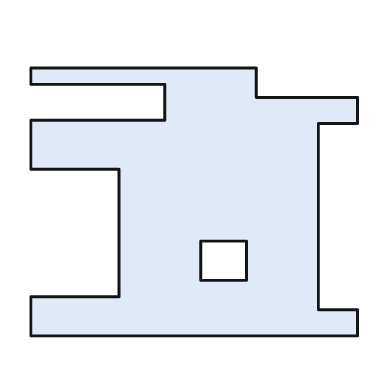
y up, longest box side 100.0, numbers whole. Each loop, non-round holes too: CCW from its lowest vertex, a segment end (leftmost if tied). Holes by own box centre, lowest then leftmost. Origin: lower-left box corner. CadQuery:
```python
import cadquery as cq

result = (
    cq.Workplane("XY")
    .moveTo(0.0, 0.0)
    .lineTo(100.0, 0.0)
    .lineTo(100.0, 8.0)
    .lineTo(88.0, 8.0)
    .lineTo(88.0, 65.0)
    .lineTo(100.0, 65.0)
    .lineTo(100.0, 73.0)
    .lineTo(69.0, 73.0)
    .lineTo(69.0, 82.0)
    .lineTo(0.0, 82.0)
    .lineTo(0.0, 77.0)
    .lineTo(41.0, 77.0)
    .lineTo(41.0, 66.0)
    .lineTo(0.0, 66.0)
    .lineTo(0.0, 51.0)
    .lineTo(27.0, 51.0)
    .lineTo(27.0, 12.0)
    .lineTo(0.0, 12.0)
    .close()
    .moveTo(52.0, 17.0)
    .lineTo(66.0, 17.0)
    .lineTo(66.0, 29.0)
    .lineTo(52.0, 29.0)
    .close()
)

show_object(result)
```